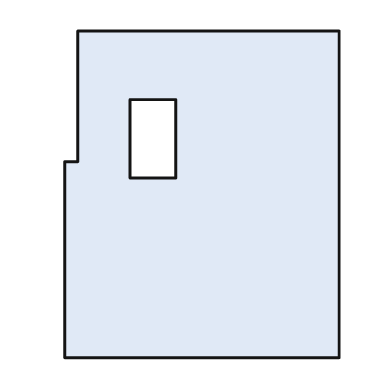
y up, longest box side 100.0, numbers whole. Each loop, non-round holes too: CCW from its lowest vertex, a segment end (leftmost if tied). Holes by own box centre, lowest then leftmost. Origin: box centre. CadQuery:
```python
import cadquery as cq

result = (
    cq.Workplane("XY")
    .moveTo(-42.0, -50.0)
    .lineTo(42.0, -50.0)
    .lineTo(42.0, 50.0)
    .lineTo(-38.0, 50.0)
    .lineTo(-38.0, 10.0)
    .lineTo(-42.0, 10.0)
    .close()
    .moveTo(-22.0, 5.0)
    .lineTo(-8.0, 5.0)
    .lineTo(-8.0, 29.0)
    .lineTo(-22.0, 29.0)
    .close()
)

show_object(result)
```